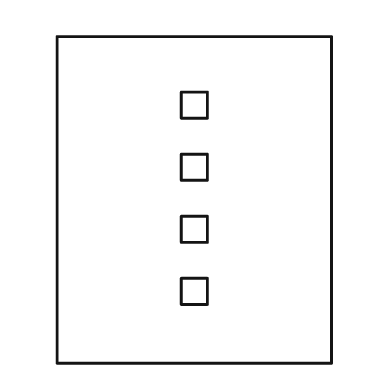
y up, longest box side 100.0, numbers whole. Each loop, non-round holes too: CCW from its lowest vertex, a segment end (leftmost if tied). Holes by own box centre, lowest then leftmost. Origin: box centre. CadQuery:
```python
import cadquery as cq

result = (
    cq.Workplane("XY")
    .moveTo(-42.0, -50.0)
    .lineTo(42.0, -50.0)
    .lineTo(42.0, 50.0)
    .lineTo(-42.0, 50.0)
    .close()
    .moveTo(-4.0, -32.0)
    .lineTo(4.0, -32.0)
    .lineTo(4.0, -24.0)
    .lineTo(-4.0, -24.0)
    .close()
    .moveTo(-4.0, -13.0)
    .lineTo(4.0, -13.0)
    .lineTo(4.0, -5.0)
    .lineTo(-4.0, -5.0)
    .close()
    .moveTo(-4.0, 6.0)
    .lineTo(4.0, 6.0)
    .lineTo(4.0, 14.0)
    .lineTo(-4.0, 14.0)
    .close()
    .moveTo(-4.0, 25.0)
    .lineTo(4.0, 25.0)
    .lineTo(4.0, 33.0)
    .lineTo(-4.0, 33.0)
    .close()
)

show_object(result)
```